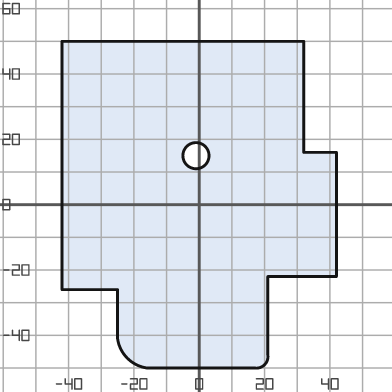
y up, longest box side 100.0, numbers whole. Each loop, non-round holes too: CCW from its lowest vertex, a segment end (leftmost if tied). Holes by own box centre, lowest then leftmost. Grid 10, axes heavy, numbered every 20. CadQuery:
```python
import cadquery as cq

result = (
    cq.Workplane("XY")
    .moveTo(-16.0, -50.0)
    .lineTo(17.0, -50.0)
    .threePointArc((20.0, -49.0), (21.0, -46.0))
    .lineTo(21.0, -22.0)
    .lineTo(42.0, -22.0)
    .lineTo(42.0, 16.0)
    .lineTo(32.0, 16.0)
    .lineTo(32.0, 50.0)
    .lineTo(-42.0, 50.0)
    .lineTo(-42.0, -26.0)
    .lineTo(-25.0, -26.0)
    .lineTo(-25.0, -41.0)
    .threePointArc((-22.0, -47.0), (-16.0, -50.0))
    .close()
    .moveTo(-1.0, 15.0)
    .circle(4.0)
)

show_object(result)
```